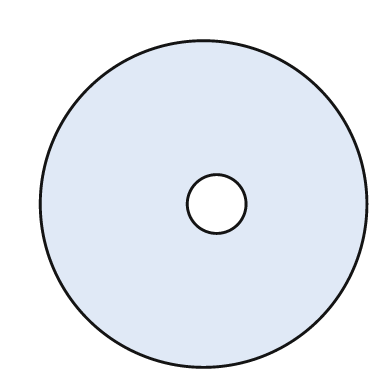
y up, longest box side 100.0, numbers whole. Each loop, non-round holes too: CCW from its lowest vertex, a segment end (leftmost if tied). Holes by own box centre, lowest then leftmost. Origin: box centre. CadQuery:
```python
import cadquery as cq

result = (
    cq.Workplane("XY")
    .moveTo(0.0, 0.0)
    .circle(50.0)
    .moveTo(4.0, 0.0)
    .circle(9.0)
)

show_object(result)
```